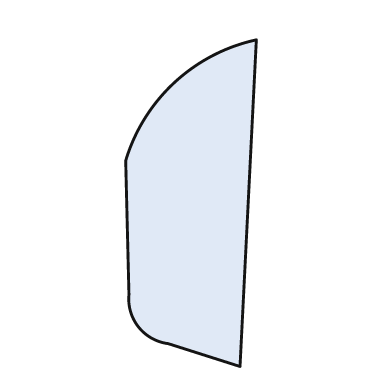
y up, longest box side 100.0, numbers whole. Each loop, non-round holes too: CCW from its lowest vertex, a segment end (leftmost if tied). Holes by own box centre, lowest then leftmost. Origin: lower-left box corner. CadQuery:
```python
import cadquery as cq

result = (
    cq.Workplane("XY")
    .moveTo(35.0, 0.0)
    .lineTo(40.0, 100.0)
    .threePointArc((15.0, 87.0), (0.0, 63.0))
    .lineTo(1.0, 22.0)
    .threePointArc((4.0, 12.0), (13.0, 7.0))
    .close()
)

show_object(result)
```